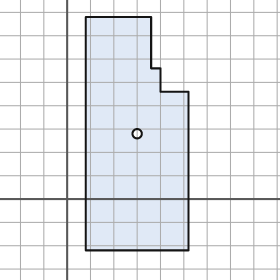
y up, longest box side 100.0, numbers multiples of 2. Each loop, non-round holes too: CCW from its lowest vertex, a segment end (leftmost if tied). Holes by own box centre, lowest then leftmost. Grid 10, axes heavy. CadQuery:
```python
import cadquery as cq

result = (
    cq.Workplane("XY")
    .moveTo(8.0, -22.0)
    .lineTo(52.0, -22.0)
    .lineTo(52.0, 46.0)
    .lineTo(40.0, 46.0)
    .lineTo(40.0, 56.0)
    .lineTo(36.0, 56.0)
    .lineTo(36.0, 78.0)
    .lineTo(8.0, 78.0)
    .close()
    .moveTo(30.0, 28.0)
    .circle(2.0)
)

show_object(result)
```